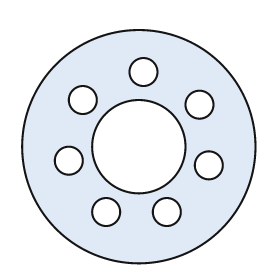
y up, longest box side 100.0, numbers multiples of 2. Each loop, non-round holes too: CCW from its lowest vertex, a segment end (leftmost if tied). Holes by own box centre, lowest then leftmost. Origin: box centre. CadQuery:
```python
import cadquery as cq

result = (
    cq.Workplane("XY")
    .moveTo(0.0, 0.0)
    .circle(50.0)
    .moveTo(-14.0, -28.0)
    .circle(6.0)
    .moveTo(12.0, -28.0)
    .circle(6.0)
    .moveTo(30.0, -8.0)
    .circle(6.0)
    .moveTo(-30.0, -6.0)
    .circle(6.0)
    .moveTo(0.0, 0.0)
    .circle(20.0)
    .moveTo(26.0, 18.0)
    .circle(6.0)
    .moveTo(-24.0, 20.0)
    .circle(6.0)
    .moveTo(2.0, 32.0)
    .circle(6.0)
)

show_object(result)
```